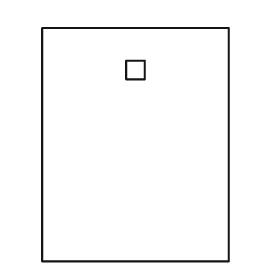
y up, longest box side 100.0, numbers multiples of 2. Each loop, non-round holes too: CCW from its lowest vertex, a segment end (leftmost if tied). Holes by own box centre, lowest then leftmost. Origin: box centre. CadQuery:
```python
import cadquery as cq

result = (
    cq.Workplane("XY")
    .moveTo(-40.0, -50.0)
    .lineTo(40.0, -50.0)
    .lineTo(40.0, 50.0)
    .lineTo(-40.0, 50.0)
    .close()
    .moveTo(-4.0, 28.0)
    .lineTo(4.0, 28.0)
    .lineTo(4.0, 36.0)
    .lineTo(-4.0, 36.0)
    .close()
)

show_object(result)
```